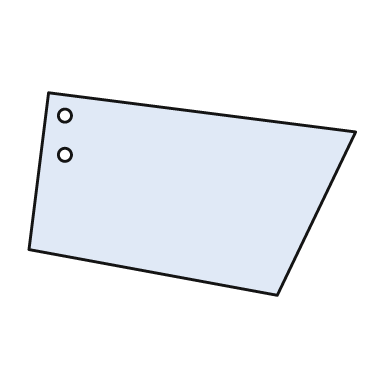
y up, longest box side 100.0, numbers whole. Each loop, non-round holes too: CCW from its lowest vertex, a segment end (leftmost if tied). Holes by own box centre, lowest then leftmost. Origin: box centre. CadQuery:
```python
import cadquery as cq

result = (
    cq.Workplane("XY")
    .moveTo(26.0, -31.0)
    .lineTo(50.0, 19.0)
    .lineTo(-44.0, 31.0)
    .lineTo(-50.0, -17.0)
    .close()
    .moveTo(-39.0, 12.0)
    .circle(2.0)
    .moveTo(-39.0, 24.0)
    .circle(2.0)
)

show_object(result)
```